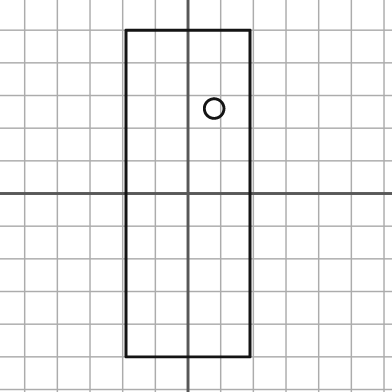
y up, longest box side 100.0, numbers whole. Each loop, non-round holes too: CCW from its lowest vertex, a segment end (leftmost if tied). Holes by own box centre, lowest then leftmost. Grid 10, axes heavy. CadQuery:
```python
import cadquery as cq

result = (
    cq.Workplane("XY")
    .moveTo(-19.0, -50.0)
    .lineTo(19.0, -50.0)
    .lineTo(19.0, 50.0)
    .lineTo(-19.0, 50.0)
    .close()
    .moveTo(8.0, 26.0)
    .circle(3.0)
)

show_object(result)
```